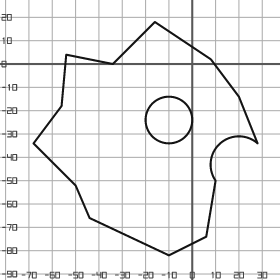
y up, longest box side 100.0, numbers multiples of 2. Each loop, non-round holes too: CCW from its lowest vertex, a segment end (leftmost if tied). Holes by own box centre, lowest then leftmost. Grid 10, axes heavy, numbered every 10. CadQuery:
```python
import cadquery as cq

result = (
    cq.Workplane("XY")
    .moveTo(-10.0, -82.0)
    .lineTo(6.0, -74.0)
    .lineTo(10.0, -50.0)
    .threePointArc((12.0, -34.0), (28.0, -34.0))
    .lineTo(20.0, -14.0)
    .lineTo(8.0, 2.0)
    .lineTo(-16.0, 18.0)
    .lineTo(-34.0, 0.0)
    .lineTo(-54.0, 4.0)
    .lineTo(-56.0, -18.0)
    .lineTo(-68.0, -34.0)
    .lineTo(-50.0, -52.0)
    .lineTo(-44.0, -66.0)
    .close()
    .moveTo(-10.0, -24.0)
    .circle(10.0)
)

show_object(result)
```